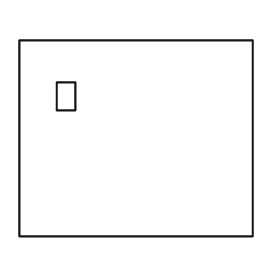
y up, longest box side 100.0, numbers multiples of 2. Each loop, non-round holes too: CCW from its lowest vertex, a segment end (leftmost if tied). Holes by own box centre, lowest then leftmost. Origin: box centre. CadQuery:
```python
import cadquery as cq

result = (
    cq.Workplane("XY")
    .moveTo(-50.0, -42.0)
    .lineTo(50.0, -42.0)
    .lineTo(50.0, 42.0)
    .lineTo(-50.0, 42.0)
    .close()
    .moveTo(-34.0, 12.0)
    .lineTo(-26.0, 12.0)
    .lineTo(-26.0, 24.0)
    .lineTo(-34.0, 24.0)
    .close()
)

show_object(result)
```